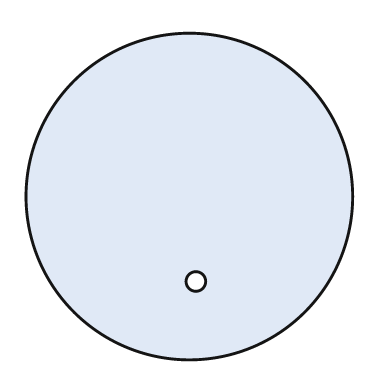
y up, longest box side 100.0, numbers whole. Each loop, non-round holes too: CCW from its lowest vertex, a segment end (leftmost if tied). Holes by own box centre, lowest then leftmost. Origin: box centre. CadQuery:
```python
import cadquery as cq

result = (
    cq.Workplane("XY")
    .moveTo(0.0, 0.0)
    .circle(50.0)
    .moveTo(2.0, -26.0)
    .circle(3.0)
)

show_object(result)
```